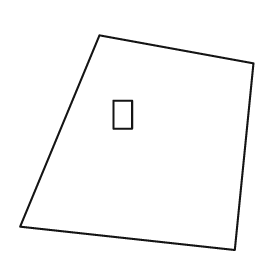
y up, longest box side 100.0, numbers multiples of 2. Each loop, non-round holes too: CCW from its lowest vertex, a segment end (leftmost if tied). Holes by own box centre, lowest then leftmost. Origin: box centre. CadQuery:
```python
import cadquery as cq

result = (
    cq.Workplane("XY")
    .moveTo(42.0, -46.0)
    .lineTo(50.0, 34.0)
    .lineTo(-16.0, 46.0)
    .lineTo(-50.0, -36.0)
    .close()
    .moveTo(-10.0, 6.0)
    .lineTo(-2.0, 6.0)
    .lineTo(-2.0, 18.0)
    .lineTo(-10.0, 18.0)
    .close()
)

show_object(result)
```